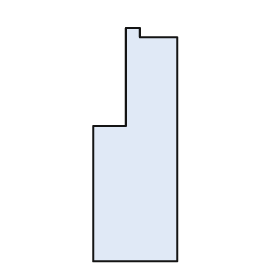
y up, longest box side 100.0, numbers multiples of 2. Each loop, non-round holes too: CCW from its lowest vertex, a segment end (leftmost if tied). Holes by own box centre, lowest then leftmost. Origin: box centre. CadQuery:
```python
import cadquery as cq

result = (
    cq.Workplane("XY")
    .moveTo(-18.0, -50.0)
    .lineTo(18.0, -50.0)
    .lineTo(18.0, 46.0)
    .lineTo(2.0, 46.0)
    .lineTo(2.0, 50.0)
    .lineTo(-4.0, 50.0)
    .lineTo(-4.0, 8.0)
    .lineTo(-18.0, 8.0)
    .close()
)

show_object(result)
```